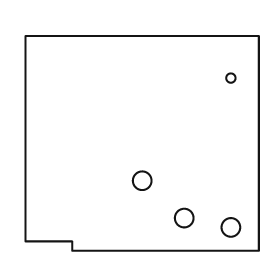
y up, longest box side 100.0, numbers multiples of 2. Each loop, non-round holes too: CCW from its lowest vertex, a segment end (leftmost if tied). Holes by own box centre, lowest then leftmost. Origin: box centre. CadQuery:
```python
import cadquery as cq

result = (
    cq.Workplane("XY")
    .moveTo(-30.0, -46.0)
    .lineTo(50.0, -46.0)
    .lineTo(50.0, 46.0)
    .lineTo(-50.0, 46.0)
    .lineTo(-50.0, -42.0)
    .lineTo(-30.0, -42.0)
    .close()
    .moveTo(38.0, -36.0)
    .circle(4.0)
    .moveTo(18.0, -32.0)
    .circle(4.0)
    .moveTo(0.0, -16.0)
    .circle(4.0)
    .moveTo(38.0, 28.0)
    .circle(2.0)
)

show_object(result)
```